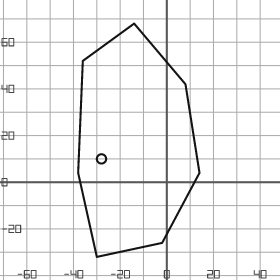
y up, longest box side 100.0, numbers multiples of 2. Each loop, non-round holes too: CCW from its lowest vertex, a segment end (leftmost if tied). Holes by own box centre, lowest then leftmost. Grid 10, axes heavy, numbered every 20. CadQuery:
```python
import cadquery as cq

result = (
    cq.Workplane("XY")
    .moveTo(-30.0, -32.0)
    .lineTo(-2.0, -26.0)
    .lineTo(14.0, 4.0)
    .lineTo(8.0, 42.0)
    .lineTo(-14.0, 68.0)
    .lineTo(-36.0, 52.0)
    .lineTo(-38.0, 4.0)
    .close()
    .moveTo(-28.0, 10.0)
    .circle(2.0)
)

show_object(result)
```